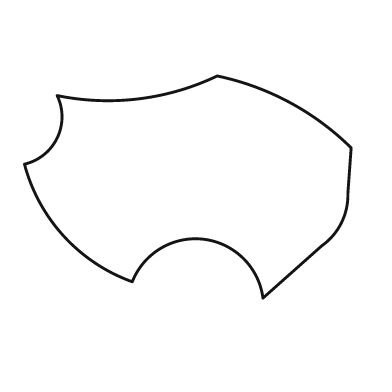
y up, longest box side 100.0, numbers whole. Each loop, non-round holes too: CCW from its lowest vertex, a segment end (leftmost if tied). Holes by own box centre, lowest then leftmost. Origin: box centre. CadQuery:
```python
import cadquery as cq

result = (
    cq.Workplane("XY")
    .moveTo(23.0, -34.0)
    .lineTo(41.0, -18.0)
    .threePointArc((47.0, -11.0), (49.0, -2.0))
    .lineTo(50.0, 12.0)
    .threePointArc((31.0, 26.0), (9.0, 34.0))
    .threePointArc((-15.0, 27.0), (-40.0, 28.0))
    .threePointArc((-40.0, 15.0), (-50.0, 7.0))
    .threePointArc((-38.0, -15.0), (-17.0, -29.0))
    .threePointArc((5.0, -16.0), (23.0, -34.0))
    .close()
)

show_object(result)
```